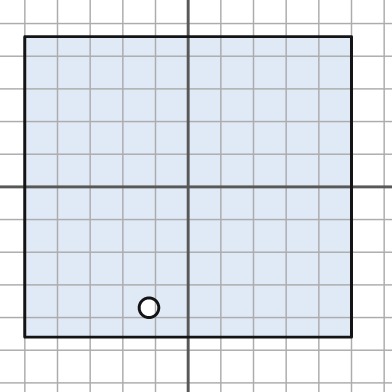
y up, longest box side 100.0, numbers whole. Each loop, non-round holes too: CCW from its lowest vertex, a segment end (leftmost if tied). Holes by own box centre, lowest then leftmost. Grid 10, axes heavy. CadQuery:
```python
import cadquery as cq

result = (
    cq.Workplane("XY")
    .moveTo(-50.0, -46.0)
    .lineTo(50.0, -46.0)
    .lineTo(50.0, 46.0)
    .lineTo(-50.0, 46.0)
    .close()
    .moveTo(-12.0, -37.0)
    .circle(3.0)
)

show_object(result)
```